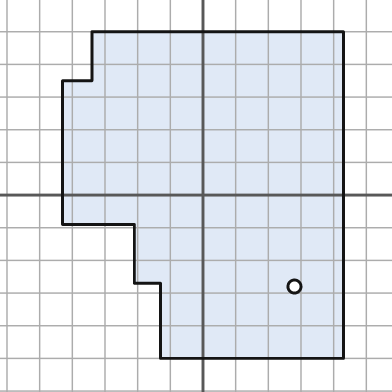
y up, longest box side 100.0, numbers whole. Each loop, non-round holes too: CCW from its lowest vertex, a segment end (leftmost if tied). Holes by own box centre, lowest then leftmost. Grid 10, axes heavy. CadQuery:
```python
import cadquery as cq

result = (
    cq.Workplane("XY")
    .moveTo(-13.0, -50.0)
    .lineTo(43.0, -50.0)
    .lineTo(43.0, 50.0)
    .lineTo(-34.0, 50.0)
    .lineTo(-34.0, 35.0)
    .lineTo(-43.0, 35.0)
    .lineTo(-43.0, -9.0)
    .lineTo(-21.0, -9.0)
    .lineTo(-21.0, -27.0)
    .lineTo(-13.0, -27.0)
    .close()
    .moveTo(28.0, -28.0)
    .circle(2.0)
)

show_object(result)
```